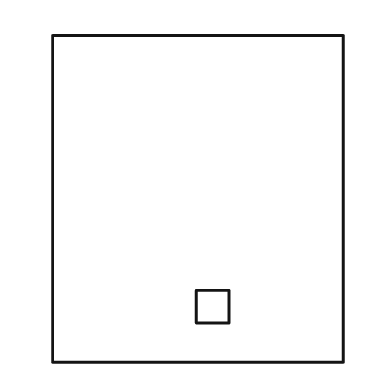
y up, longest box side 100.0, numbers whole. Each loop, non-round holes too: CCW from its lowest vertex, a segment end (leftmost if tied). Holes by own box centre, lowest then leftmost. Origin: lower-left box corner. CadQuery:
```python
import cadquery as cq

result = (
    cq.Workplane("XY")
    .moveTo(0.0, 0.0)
    .lineTo(89.0, 0.0)
    .lineTo(89.0, 100.0)
    .lineTo(0.0, 100.0)
    .close()
    .moveTo(44.0, 12.0)
    .lineTo(54.0, 12.0)
    .lineTo(54.0, 22.0)
    .lineTo(44.0, 22.0)
    .close()
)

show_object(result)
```